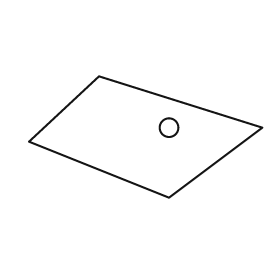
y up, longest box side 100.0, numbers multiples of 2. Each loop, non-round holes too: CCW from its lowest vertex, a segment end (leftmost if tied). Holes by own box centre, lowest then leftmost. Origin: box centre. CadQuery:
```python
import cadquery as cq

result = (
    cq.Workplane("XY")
    .moveTo(10.0, -26.0)
    .lineTo(50.0, 4.0)
    .lineTo(-20.0, 26.0)
    .lineTo(-50.0, -2.0)
    .close()
    .moveTo(10.0, 4.0)
    .circle(4.0)
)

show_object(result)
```